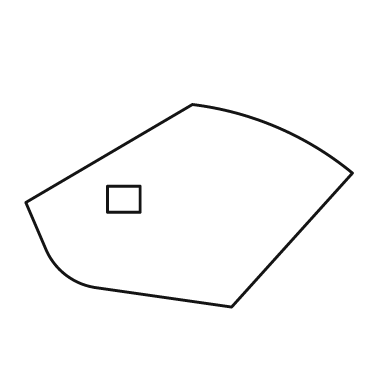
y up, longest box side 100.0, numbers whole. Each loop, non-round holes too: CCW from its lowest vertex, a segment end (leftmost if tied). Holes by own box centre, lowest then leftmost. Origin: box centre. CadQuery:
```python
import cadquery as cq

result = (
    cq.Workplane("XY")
    .moveTo(13.0, -31.0)
    .lineTo(50.0, 10.0)
    .threePointArc((27.0, 24.0), (1.0, 31.0))
    .lineTo(-50.0, 1.0)
    .lineTo(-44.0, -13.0)
    .threePointArc((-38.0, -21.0), (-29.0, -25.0))
    .close()
    .moveTo(-25.0, -2.0)
    .lineTo(-15.0, -2.0)
    .lineTo(-15.0, 6.0)
    .lineTo(-25.0, 6.0)
    .close()
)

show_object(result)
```